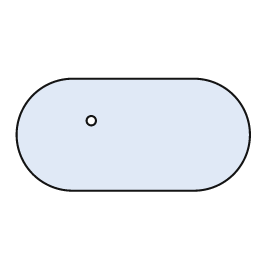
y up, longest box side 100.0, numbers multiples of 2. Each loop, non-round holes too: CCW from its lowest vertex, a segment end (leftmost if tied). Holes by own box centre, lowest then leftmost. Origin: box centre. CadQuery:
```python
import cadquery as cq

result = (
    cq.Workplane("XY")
    .moveTo(-26.0, -24.0)
    .lineTo(26.0, -24.0)
    .threePointArc((50.0, 0.0), (26.0, 24.0))
    .lineTo(-26.0, 24.0)
    .threePointArc((-50.0, 0.0), (-26.0, -24.0))
    .close()
    .moveTo(-18.0, 6.0)
    .circle(2.0)
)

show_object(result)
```